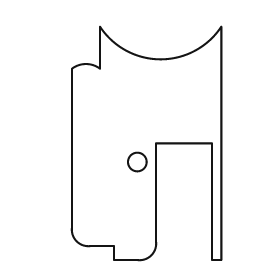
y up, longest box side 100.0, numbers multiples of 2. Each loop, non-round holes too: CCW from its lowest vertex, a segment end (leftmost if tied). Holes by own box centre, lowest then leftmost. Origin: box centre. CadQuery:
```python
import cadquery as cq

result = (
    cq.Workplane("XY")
    .moveTo(-14.0, -50.0)
    .lineTo(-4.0, -50.0)
    .threePointArc((2.0, -48.0), (4.0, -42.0))
    .lineTo(4.0, 0.0)
    .lineTo(28.0, 0.0)
    .lineTo(28.0, -50.0)
    .lineTo(32.0, -50.0)
    .lineTo(32.0, 50.0)
    .threePointArc((6.0, 36.0), (-20.0, 50.0))
    .lineTo(-20.0, 32.0)
    .threePointArc((-26.0, 34.0), (-32.0, 32.0))
    .lineTo(-32.0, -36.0)
    .threePointArc((-30.0, -42.0), (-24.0, -44.0))
    .lineTo(-14.0, -44.0)
    .close()
    .moveTo(-4.0, -8.0)
    .circle(4.0)
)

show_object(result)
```